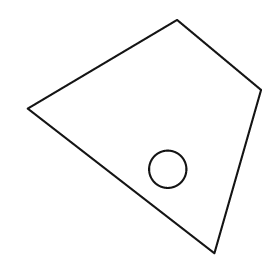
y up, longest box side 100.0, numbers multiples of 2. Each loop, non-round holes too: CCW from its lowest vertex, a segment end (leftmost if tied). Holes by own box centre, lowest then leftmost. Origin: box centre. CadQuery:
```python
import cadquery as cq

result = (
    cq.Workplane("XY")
    .moveTo(30.0, -50.0)
    .lineTo(50.0, 20.0)
    .lineTo(14.0, 50.0)
    .lineTo(-50.0, 12.0)
    .close()
    .moveTo(10.0, -14.0)
    .circle(8.0)
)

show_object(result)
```